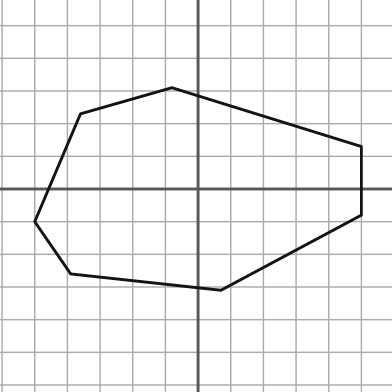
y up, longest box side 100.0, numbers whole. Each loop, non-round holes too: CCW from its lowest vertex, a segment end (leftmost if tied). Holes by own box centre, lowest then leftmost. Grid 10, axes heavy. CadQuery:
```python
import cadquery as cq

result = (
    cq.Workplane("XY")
    .moveTo(7.0, -31.0)
    .lineTo(50.0, -8.0)
    .lineTo(50.0, 13.0)
    .lineTo(-8.0, 31.0)
    .lineTo(-36.0, 23.0)
    .lineTo(-50.0, -10.0)
    .lineTo(-39.0, -26.0)
    .close()
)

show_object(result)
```